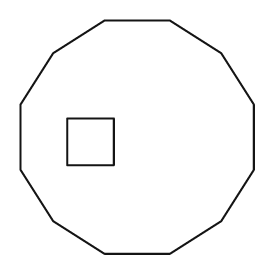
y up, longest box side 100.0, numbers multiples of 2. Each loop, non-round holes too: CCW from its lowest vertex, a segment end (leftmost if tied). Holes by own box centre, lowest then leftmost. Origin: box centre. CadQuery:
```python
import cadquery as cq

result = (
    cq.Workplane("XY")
    .moveTo(-14.0, -50.0)
    .lineTo(14.0, -50.0)
    .lineTo(36.0, -36.0)
    .lineTo(50.0, -14.0)
    .lineTo(50.0, 14.0)
    .lineTo(36.0, 36.0)
    .lineTo(14.0, 50.0)
    .lineTo(-14.0, 50.0)
    .lineTo(-36.0, 36.0)
    .lineTo(-50.0, 14.0)
    .lineTo(-50.0, -14.0)
    .lineTo(-36.0, -36.0)
    .close()
    .moveTo(-30.0, -12.0)
    .lineTo(-10.0, -12.0)
    .lineTo(-10.0, 8.0)
    .lineTo(-30.0, 8.0)
    .close()
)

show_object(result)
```